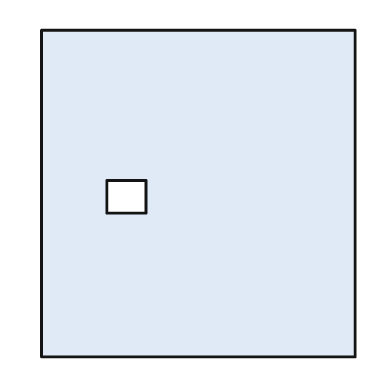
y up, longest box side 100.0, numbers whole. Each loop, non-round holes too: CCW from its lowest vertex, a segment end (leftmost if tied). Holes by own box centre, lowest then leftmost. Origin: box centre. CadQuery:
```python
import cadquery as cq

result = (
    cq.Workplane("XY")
    .moveTo(-48.0, -50.0)
    .lineTo(48.0, -50.0)
    .lineTo(48.0, 50.0)
    .lineTo(-48.0, 50.0)
    .close()
    .moveTo(-28.0, -6.0)
    .lineTo(-16.0, -6.0)
    .lineTo(-16.0, 4.0)
    .lineTo(-28.0, 4.0)
    .close()
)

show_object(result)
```